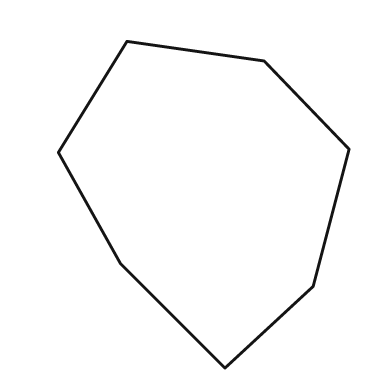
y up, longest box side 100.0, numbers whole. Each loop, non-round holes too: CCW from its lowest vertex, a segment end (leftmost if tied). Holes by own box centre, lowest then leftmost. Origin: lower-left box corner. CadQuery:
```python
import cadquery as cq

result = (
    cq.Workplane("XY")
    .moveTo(51.0, 0.0)
    .lineTo(78.0, 25.0)
    .lineTo(89.0, 67.0)
    .lineTo(63.0, 94.0)
    .lineTo(21.0, 100.0)
    .lineTo(0.0, 66.0)
    .lineTo(19.0, 32.0)
    .close()
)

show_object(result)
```